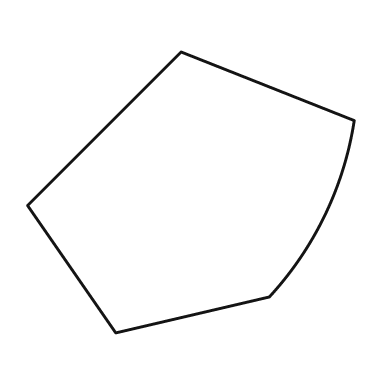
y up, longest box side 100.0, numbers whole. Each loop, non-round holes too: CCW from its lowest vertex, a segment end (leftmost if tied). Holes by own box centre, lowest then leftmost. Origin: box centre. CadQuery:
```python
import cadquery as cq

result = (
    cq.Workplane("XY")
    .moveTo(-23.0, -43.0)
    .lineTo(24.0, -32.0)
    .threePointArc((41.0, -7.0), (50.0, 22.0))
    .lineTo(-3.0, 43.0)
    .lineTo(-50.0, -4.0)
    .close()
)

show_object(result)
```